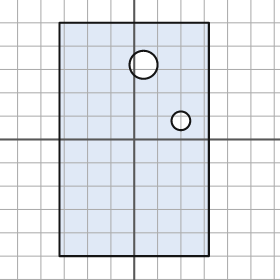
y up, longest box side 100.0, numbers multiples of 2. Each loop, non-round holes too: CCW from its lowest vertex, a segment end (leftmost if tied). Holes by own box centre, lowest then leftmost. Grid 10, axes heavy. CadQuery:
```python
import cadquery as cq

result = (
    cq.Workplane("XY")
    .moveTo(-32.0, -50.0)
    .lineTo(32.0, -50.0)
    .lineTo(32.0, 50.0)
    .lineTo(-32.0, 50.0)
    .close()
    .moveTo(20.0, 8.0)
    .circle(4.0)
    .moveTo(4.0, 32.0)
    .circle(6.0)
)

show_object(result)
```